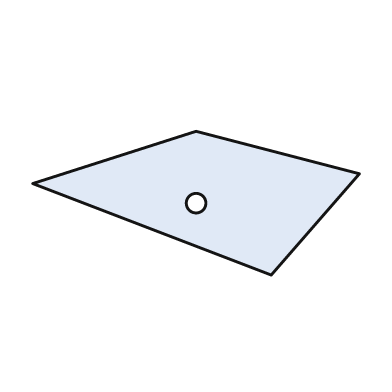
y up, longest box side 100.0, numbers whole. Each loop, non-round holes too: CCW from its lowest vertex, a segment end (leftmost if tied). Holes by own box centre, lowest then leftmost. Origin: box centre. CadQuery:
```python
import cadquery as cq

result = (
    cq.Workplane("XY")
    .moveTo(23.0, -22.0)
    .lineTo(50.0, 9.0)
    .lineTo(0.0, 22.0)
    .lineTo(-50.0, 6.0)
    .close()
    .moveTo(0.0, 0.0)
    .circle(3.0)
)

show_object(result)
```